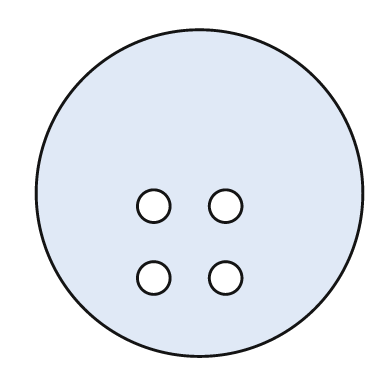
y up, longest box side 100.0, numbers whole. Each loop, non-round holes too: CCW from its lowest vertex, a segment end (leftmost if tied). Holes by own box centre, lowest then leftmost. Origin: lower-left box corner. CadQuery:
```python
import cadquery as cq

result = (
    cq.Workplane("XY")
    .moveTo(50.0, 50.0)
    .circle(50.0)
    .moveTo(36.0, 24.0)
    .circle(5.0)
    .moveTo(58.0, 24.0)
    .circle(5.0)
    .moveTo(36.0, 46.0)
    .circle(5.0)
    .moveTo(58.0, 46.0)
    .circle(5.0)
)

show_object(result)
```